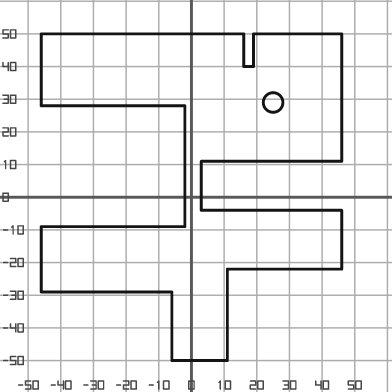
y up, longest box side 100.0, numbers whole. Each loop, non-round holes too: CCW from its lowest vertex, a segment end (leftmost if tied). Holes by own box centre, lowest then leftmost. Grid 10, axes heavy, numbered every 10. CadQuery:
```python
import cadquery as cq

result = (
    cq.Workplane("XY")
    .moveTo(-6.0, -50.0)
    .lineTo(11.0, -50.0)
    .lineTo(11.0, -22.0)
    .lineTo(46.0, -22.0)
    .lineTo(46.0, -4.0)
    .lineTo(3.0, -4.0)
    .lineTo(3.0, 11.0)
    .lineTo(46.0, 11.0)
    .lineTo(46.0, 50.0)
    .lineTo(19.0, 50.0)
    .lineTo(19.0, 40.0)
    .lineTo(16.0, 40.0)
    .lineTo(16.0, 50.0)
    .lineTo(-46.0, 50.0)
    .lineTo(-46.0, 28.0)
    .lineTo(-2.0, 28.0)
    .lineTo(-2.0, -9.0)
    .lineTo(-46.0, -9.0)
    .lineTo(-46.0, -29.0)
    .lineTo(-6.0, -29.0)
    .close()
    .moveTo(25.0, 29.0)
    .circle(3.0)
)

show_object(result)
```